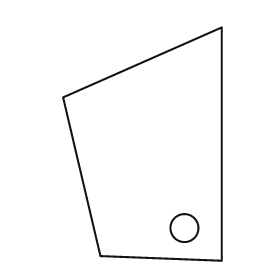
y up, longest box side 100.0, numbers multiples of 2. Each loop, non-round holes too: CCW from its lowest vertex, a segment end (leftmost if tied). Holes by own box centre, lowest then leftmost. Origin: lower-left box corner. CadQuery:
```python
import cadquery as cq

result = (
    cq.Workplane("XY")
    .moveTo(68.0, 0.0)
    .lineTo(68.0, 100.0)
    .lineTo(0.0, 70.0)
    .lineTo(16.0, 2.0)
    .close()
    .moveTo(52.0, 14.0)
    .circle(6.0)
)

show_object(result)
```